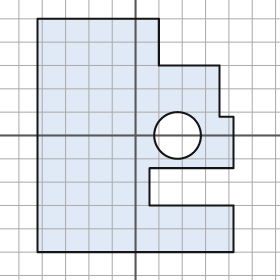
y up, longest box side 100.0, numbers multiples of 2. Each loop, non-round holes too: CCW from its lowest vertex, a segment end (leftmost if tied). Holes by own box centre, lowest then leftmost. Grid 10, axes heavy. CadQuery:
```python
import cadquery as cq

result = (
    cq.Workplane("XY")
    .moveTo(-42.0, -50.0)
    .lineTo(42.0, -50.0)
    .lineTo(42.0, -30.0)
    .lineTo(6.0, -30.0)
    .lineTo(6.0, -14.0)
    .lineTo(42.0, -14.0)
    .lineTo(42.0, 8.0)
    .lineTo(36.0, 8.0)
    .lineTo(36.0, 30.0)
    .lineTo(10.0, 30.0)
    .lineTo(10.0, 50.0)
    .lineTo(-42.0, 50.0)
    .close()
    .moveTo(18.0, 0.0)
    .circle(10.0)
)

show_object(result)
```